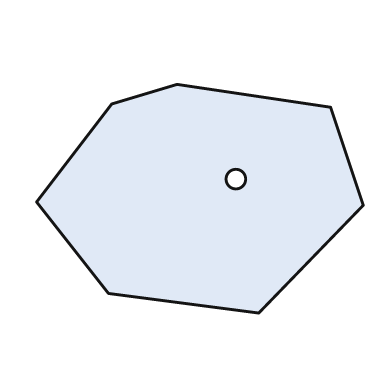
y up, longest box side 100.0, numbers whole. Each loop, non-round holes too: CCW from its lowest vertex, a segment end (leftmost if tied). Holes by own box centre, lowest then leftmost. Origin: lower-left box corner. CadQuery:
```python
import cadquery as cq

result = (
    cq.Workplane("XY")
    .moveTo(68.0, 0.0)
    .lineTo(100.0, 33.0)
    .lineTo(90.0, 63.0)
    .lineTo(43.0, 70.0)
    .lineTo(23.0, 64.0)
    .lineTo(0.0, 34.0)
    .lineTo(22.0, 6.0)
    .close()
    .moveTo(61.0, 41.0)
    .circle(3.0)
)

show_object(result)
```